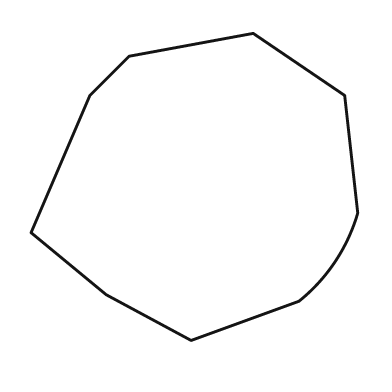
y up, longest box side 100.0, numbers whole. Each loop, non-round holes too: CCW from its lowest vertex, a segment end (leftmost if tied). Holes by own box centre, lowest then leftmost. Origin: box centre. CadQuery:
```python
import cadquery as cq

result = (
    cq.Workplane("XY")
    .moveTo(-1.0, -47.0)
    .lineTo(32.0, -35.0)
    .threePointArc((43.0, -23.0), (50.0, -8.0))
    .lineTo(46.0, 28.0)
    .lineTo(18.0, 47.0)
    .lineTo(-20.0, 40.0)
    .lineTo(-32.0, 28.0)
    .lineTo(-50.0, -14.0)
    .lineTo(-27.0, -33.0)
    .close()
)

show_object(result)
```